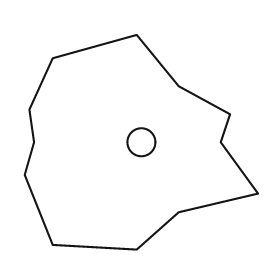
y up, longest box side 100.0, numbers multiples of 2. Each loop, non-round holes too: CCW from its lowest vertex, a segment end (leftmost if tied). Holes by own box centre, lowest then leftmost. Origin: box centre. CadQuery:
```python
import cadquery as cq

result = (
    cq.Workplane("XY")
    .moveTo(-2.0, -46.0)
    .lineTo(16.0, -30.0)
    .lineTo(50.0, -22.0)
    .lineTo(34.0, 0.0)
    .lineTo(38.0, 12.0)
    .lineTo(16.0, 24.0)
    .lineTo(-2.0, 46.0)
    .lineTo(-38.0, 36.0)
    .lineTo(-48.0, 14.0)
    .lineTo(-46.0, 0.0)
    .lineTo(-50.0, -14.0)
    .lineTo(-38.0, -44.0)
    .close()
    .moveTo(0.0, 0.0)
    .circle(6.0)
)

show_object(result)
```